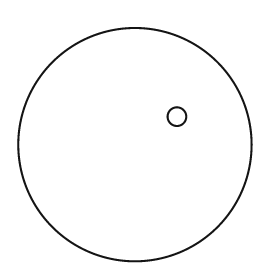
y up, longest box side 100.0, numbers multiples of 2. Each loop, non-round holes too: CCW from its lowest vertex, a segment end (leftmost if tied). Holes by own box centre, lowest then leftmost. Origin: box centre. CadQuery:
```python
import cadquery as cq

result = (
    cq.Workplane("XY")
    .moveTo(0.0, 0.0)
    .circle(50.0)
    .moveTo(18.0, 12.0)
    .circle(4.0)
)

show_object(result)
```